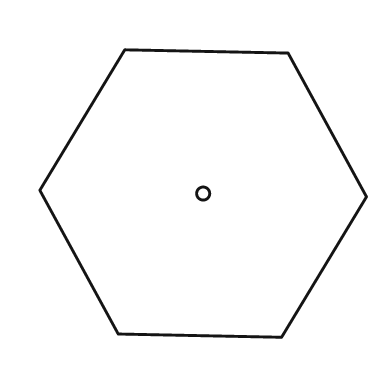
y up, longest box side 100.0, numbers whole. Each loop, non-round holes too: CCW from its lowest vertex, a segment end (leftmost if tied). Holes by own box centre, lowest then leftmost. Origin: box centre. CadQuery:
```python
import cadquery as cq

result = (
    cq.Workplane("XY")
    .moveTo(24.0, -44.0)
    .lineTo(50.0, -1.0)
    .lineTo(26.0, 43.0)
    .lineTo(-24.0, 44.0)
    .lineTo(-50.0, 1.0)
    .lineTo(-26.0, -43.0)
    .close()
    .moveTo(0.0, 0.0)
    .circle(2.0)
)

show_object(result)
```